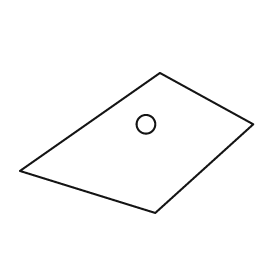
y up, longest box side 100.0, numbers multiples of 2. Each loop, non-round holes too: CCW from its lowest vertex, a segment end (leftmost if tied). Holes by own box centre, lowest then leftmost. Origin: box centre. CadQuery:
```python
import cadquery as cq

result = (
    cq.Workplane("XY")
    .moveTo(8.0, -30.0)
    .lineTo(50.0, 8.0)
    .lineTo(10.0, 30.0)
    .lineTo(-50.0, -12.0)
    .close()
    .moveTo(4.0, 8.0)
    .circle(4.0)
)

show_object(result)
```